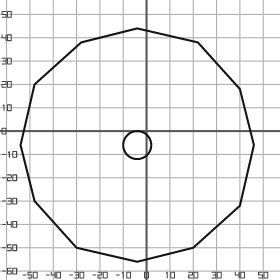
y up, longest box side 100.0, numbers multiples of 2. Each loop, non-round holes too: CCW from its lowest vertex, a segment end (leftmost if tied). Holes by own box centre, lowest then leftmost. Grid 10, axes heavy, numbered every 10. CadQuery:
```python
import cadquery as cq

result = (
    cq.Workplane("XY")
    .moveTo(-4.0, -56.0)
    .lineTo(20.0, -50.0)
    .lineTo(40.0, -32.0)
    .lineTo(46.0, -6.0)
    .lineTo(40.0, 18.0)
    .lineTo(22.0, 38.0)
    .lineTo(-4.0, 44.0)
    .lineTo(-28.0, 38.0)
    .lineTo(-48.0, 20.0)
    .lineTo(-54.0, -6.0)
    .lineTo(-48.0, -30.0)
    .lineTo(-30.0, -50.0)
    .close()
    .moveTo(-4.0, -6.0)
    .circle(6.0)
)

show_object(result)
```